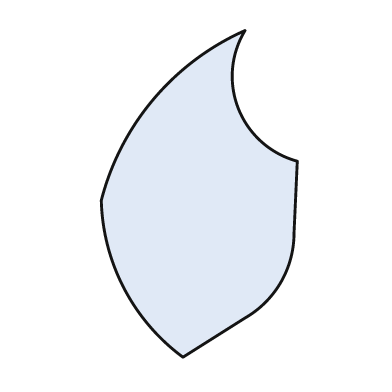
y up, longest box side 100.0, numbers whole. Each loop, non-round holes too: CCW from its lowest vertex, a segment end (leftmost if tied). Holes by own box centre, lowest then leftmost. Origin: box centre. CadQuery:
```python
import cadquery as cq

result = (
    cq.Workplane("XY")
    .moveTo(-5.0, -50.0)
    .lineTo(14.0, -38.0)
    .threePointArc((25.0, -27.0), (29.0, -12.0))
    .lineTo(30.0, 10.0)
    .threePointArc((12.0, 26.0), (14.0, 50.0))
    .threePointArc((-14.0, 29.0), (-30.0, -2.0))
    .threePointArc((-23.0, -29.0), (-5.0, -50.0))
    .close()
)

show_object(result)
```